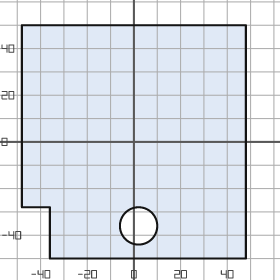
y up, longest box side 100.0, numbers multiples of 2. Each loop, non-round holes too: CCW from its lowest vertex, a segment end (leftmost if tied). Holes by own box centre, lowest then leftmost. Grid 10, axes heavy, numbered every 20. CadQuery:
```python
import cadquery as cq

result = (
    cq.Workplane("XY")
    .moveTo(-36.0, -50.0)
    .lineTo(48.0, -50.0)
    .lineTo(48.0, 50.0)
    .lineTo(-48.0, 50.0)
    .lineTo(-48.0, -28.0)
    .lineTo(-36.0, -28.0)
    .close()
    .moveTo(2.0, -36.0)
    .circle(8.0)
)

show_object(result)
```